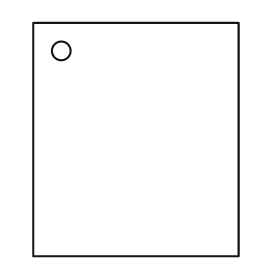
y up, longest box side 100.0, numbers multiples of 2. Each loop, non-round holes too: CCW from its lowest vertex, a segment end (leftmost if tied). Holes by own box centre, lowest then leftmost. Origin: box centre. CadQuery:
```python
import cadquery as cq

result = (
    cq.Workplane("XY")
    .moveTo(-44.0, -50.0)
    .lineTo(44.0, -50.0)
    .lineTo(44.0, 50.0)
    .lineTo(-44.0, 50.0)
    .close()
    .moveTo(-32.0, 38.0)
    .circle(4.0)
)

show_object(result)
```